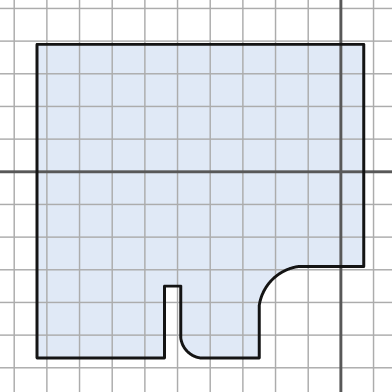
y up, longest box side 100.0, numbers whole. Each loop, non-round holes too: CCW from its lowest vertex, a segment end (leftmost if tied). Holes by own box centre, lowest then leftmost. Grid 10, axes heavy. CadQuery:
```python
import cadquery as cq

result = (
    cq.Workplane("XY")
    .moveTo(-93.0, -57.0)
    .lineTo(-54.0, -57.0)
    .lineTo(-54.0, -35.0)
    .lineTo(-49.0, -35.0)
    .lineTo(-49.0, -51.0)
    .threePointArc((-47.0, -55.0), (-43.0, -57.0))
    .lineTo(-25.0, -57.0)
    .lineTo(-25.0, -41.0)
    .threePointArc((-21.0, -33.0), (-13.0, -29.0))
    .lineTo(7.0, -29.0)
    .lineTo(7.0, 39.0)
    .lineTo(-93.0, 39.0)
    .close()
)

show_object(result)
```